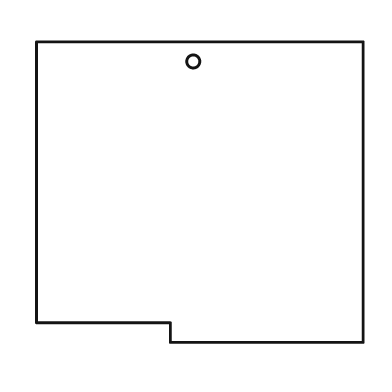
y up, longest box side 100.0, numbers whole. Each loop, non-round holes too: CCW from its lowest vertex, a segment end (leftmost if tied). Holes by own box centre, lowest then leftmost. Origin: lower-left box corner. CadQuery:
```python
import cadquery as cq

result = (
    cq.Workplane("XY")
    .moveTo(41.0, 0.0)
    .lineTo(100.0, 0.0)
    .lineTo(100.0, 92.0)
    .lineTo(0.0, 92.0)
    .lineTo(0.0, 6.0)
    .lineTo(41.0, 6.0)
    .close()
    .moveTo(48.0, 86.0)
    .circle(2.0)
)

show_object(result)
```